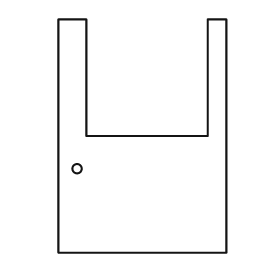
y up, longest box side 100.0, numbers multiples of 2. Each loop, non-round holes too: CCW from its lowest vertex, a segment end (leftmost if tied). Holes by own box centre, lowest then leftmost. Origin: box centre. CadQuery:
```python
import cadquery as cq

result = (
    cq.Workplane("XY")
    .moveTo(-36.0, -50.0)
    .lineTo(36.0, -50.0)
    .lineTo(36.0, 50.0)
    .lineTo(28.0, 50.0)
    .lineTo(28.0, 0.0)
    .lineTo(-24.0, 0.0)
    .lineTo(-24.0, 50.0)
    .lineTo(-36.0, 50.0)
    .close()
    .moveTo(-28.0, -14.0)
    .circle(2.0)
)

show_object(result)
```